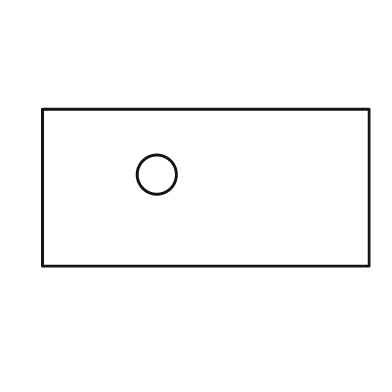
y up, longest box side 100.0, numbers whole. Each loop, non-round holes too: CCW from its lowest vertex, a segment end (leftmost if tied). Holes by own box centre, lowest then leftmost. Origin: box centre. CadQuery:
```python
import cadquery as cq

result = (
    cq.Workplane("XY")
    .moveTo(-50.0, -24.0)
    .lineTo(50.0, -24.0)
    .lineTo(50.0, 24.0)
    .lineTo(-50.0, 24.0)
    .close()
    .moveTo(-15.0, 4.0)
    .circle(6.0)
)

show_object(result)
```